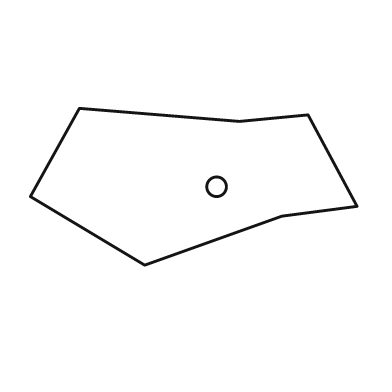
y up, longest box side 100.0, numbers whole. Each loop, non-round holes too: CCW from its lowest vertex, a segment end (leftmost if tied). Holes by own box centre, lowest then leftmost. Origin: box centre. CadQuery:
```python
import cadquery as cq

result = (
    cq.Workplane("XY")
    .moveTo(-15.0, -24.0)
    .lineTo(27.0, -9.0)
    .lineTo(50.0, -6.0)
    .lineTo(35.0, 22.0)
    .lineTo(14.0, 20.0)
    .lineTo(-35.0, 24.0)
    .lineTo(-50.0, -3.0)
    .close()
    .moveTo(7.0, 0.0)
    .circle(3.0)
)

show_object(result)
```